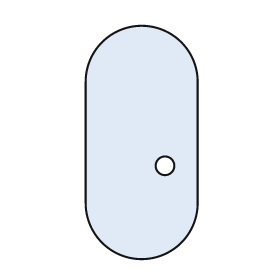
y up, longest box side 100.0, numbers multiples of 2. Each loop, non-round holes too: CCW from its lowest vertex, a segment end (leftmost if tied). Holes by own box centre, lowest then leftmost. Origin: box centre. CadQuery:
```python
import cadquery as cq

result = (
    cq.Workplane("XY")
    .moveTo(-24.0, -26.0)
    .threePointArc((0.0, -50.0), (24.0, -26.0))
    .lineTo(24.0, 26.0)
    .threePointArc((0.0, 50.0), (-24.0, 26.0))
    .close()
    .moveTo(10.0, -10.0)
    .circle(4.0)
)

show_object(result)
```